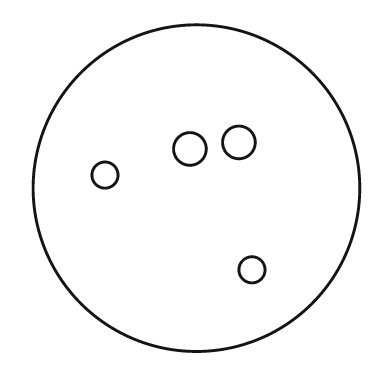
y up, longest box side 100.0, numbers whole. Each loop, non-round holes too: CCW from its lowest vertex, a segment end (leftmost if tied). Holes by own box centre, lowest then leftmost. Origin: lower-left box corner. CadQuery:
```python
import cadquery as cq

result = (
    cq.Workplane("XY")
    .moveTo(50.0, 50.0)
    .circle(50.0)
    .moveTo(67.0, 25.0)
    .circle(4.0)
    .moveTo(22.0, 54.0)
    .circle(4.0)
    .moveTo(48.0, 62.0)
    .circle(5.0)
    .moveTo(63.0, 64.0)
    .circle(5.0)
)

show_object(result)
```